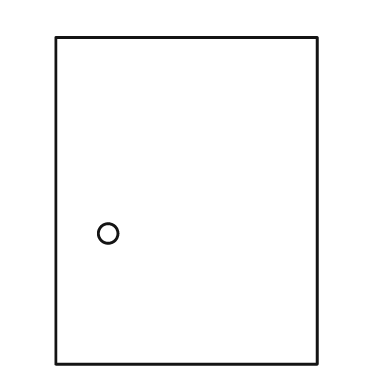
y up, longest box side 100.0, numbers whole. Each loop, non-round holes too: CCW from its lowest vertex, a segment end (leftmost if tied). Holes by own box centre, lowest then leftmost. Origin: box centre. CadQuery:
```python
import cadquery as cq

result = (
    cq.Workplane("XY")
    .moveTo(-40.0, -50.0)
    .lineTo(40.0, -50.0)
    .lineTo(40.0, 50.0)
    .lineTo(-40.0, 50.0)
    .close()
    .moveTo(-24.0, -10.0)
    .circle(3.0)
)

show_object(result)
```